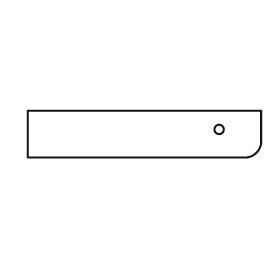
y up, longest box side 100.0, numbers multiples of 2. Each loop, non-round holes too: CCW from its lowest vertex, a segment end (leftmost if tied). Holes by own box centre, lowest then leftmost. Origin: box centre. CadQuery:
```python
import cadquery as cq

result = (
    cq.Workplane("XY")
    .moveTo(-50.0, -10.0)
    .lineTo(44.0, -10.0)
    .threePointArc((48.0, -8.0), (50.0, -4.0))
    .lineTo(50.0, 10.0)
    .lineTo(-50.0, 10.0)
    .close()
    .moveTo(32.0, 2.0)
    .circle(2.0)
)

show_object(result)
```